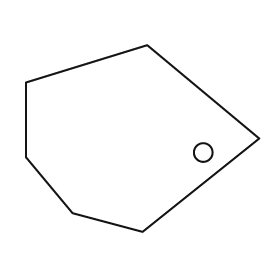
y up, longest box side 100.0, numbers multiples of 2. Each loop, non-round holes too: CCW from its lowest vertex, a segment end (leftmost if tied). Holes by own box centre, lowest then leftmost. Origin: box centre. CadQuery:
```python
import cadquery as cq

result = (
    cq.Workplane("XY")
    .moveTo(0.0, -40.0)
    .lineTo(50.0, 0.0)
    .lineTo(2.0, 40.0)
    .lineTo(-50.0, 24.0)
    .lineTo(-50.0, -8.0)
    .lineTo(-30.0, -32.0)
    .close()
    .moveTo(26.0, -6.0)
    .circle(4.0)
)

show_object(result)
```